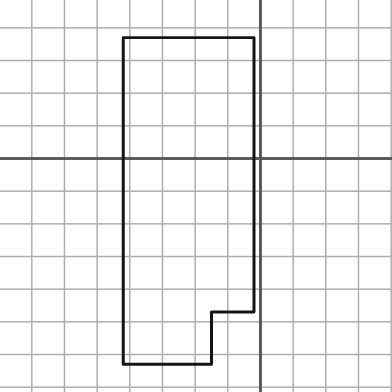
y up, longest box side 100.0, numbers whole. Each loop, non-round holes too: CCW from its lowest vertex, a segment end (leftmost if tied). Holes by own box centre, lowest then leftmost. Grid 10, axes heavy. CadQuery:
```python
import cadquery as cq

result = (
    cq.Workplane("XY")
    .moveTo(-42.0, -63.0)
    .lineTo(-15.0, -63.0)
    .lineTo(-15.0, -47.0)
    .lineTo(-2.0, -47.0)
    .lineTo(-2.0, 37.0)
    .lineTo(-42.0, 37.0)
    .close()
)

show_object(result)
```